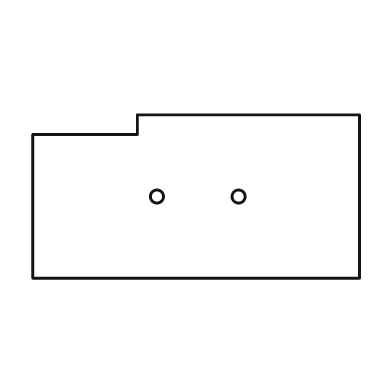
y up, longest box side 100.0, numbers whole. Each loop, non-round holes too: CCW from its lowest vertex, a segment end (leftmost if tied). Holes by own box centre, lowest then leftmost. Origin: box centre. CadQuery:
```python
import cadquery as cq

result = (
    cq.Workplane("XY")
    .moveTo(-50.0, -25.0)
    .lineTo(50.0, -25.0)
    .lineTo(50.0, 25.0)
    .lineTo(-18.0, 25.0)
    .lineTo(-18.0, 19.0)
    .lineTo(-50.0, 19.0)
    .close()
    .moveTo(-12.0, 0.0)
    .circle(2.0)
    .moveTo(13.0, 0.0)
    .circle(2.0)
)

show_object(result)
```